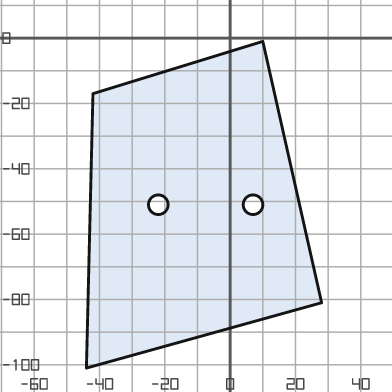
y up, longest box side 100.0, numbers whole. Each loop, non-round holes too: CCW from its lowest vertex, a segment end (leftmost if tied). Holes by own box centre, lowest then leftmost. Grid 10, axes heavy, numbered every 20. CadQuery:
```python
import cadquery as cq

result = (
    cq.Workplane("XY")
    .moveTo(-44.0, -101.0)
    .lineTo(28.0, -81.0)
    .lineTo(10.0, -1.0)
    .lineTo(-42.0, -17.0)
    .close()
    .moveTo(-22.0, -51.0)
    .circle(3.0)
    .moveTo(7.0, -51.0)
    .circle(3.0)
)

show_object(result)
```